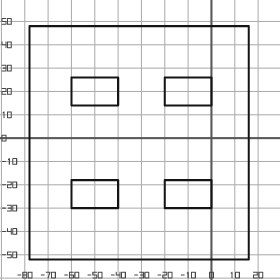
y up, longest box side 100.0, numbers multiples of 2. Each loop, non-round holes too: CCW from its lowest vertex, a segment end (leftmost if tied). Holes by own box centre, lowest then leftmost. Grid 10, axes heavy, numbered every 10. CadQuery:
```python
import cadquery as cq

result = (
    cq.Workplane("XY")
    .moveTo(-78.0, -52.0)
    .lineTo(16.0, -52.0)
    .lineTo(16.0, 48.0)
    .lineTo(-78.0, 48.0)
    .close()
    .moveTo(-60.0, -30.0)
    .lineTo(-40.0, -30.0)
    .lineTo(-40.0, -18.0)
    .lineTo(-60.0, -18.0)
    .close()
    .moveTo(-20.0, -30.0)
    .lineTo(0.0, -30.0)
    .lineTo(0.0, -18.0)
    .lineTo(-20.0, -18.0)
    .close()
    .moveTo(-60.0, 14.0)
    .lineTo(-40.0, 14.0)
    .lineTo(-40.0, 26.0)
    .lineTo(-60.0, 26.0)
    .close()
    .moveTo(-20.0, 14.0)
    .lineTo(0.0, 14.0)
    .lineTo(0.0, 26.0)
    .lineTo(-20.0, 26.0)
    .close()
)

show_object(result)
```